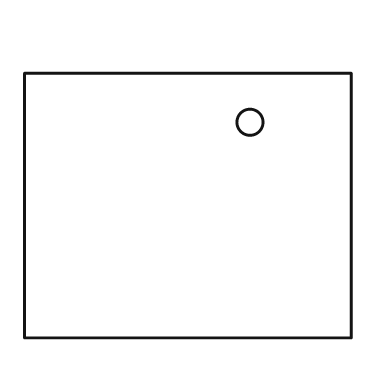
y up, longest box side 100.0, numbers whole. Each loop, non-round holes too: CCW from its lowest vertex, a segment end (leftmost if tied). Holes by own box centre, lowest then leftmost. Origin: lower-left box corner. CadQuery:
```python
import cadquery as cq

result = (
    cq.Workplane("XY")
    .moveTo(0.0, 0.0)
    .lineTo(100.0, 0.0)
    .lineTo(100.0, 81.0)
    .lineTo(0.0, 81.0)
    .close()
    .moveTo(69.0, 66.0)
    .circle(4.0)
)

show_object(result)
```